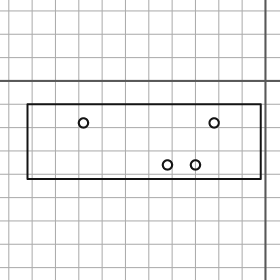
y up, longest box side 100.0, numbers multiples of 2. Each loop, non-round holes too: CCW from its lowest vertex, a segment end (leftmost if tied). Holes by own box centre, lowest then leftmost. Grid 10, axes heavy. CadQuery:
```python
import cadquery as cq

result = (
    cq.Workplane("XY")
    .moveTo(-102.0, -42.0)
    .lineTo(-2.0, -42.0)
    .lineTo(-2.0, -10.0)
    .lineTo(-102.0, -10.0)
    .close()
    .moveTo(-42.0, -36.0)
    .circle(2.0)
    .moveTo(-30.0, -36.0)
    .circle(2.0)
    .moveTo(-78.0, -18.0)
    .circle(2.0)
    .moveTo(-22.0, -18.0)
    .circle(2.0)
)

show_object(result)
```